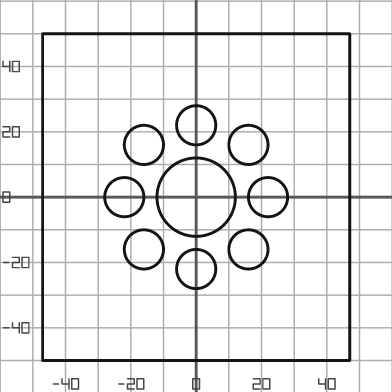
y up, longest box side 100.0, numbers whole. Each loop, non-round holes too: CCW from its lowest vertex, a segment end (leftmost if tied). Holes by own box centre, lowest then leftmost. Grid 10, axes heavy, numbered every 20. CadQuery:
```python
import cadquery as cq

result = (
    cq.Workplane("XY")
    .moveTo(-47.0, -50.0)
    .lineTo(47.0, -50.0)
    .lineTo(47.0, 50.0)
    .lineTo(-47.0, 50.0)
    .close()
    .moveTo(0.0, -22.0)
    .circle(6.0)
    .moveTo(-16.0, -16.0)
    .circle(6.0)
    .moveTo(16.0, -16.0)
    .circle(6.0)
    .moveTo(-22.0, 0.0)
    .circle(6.0)
    .moveTo(0.0, 0.0)
    .circle(12.0)
    .moveTo(22.0, 0.0)
    .circle(6.0)
    .moveTo(-16.0, 16.0)
    .circle(6.0)
    .moveTo(16.0, 16.0)
    .circle(6.0)
    .moveTo(0.0, 22.0)
    .circle(6.0)
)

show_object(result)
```